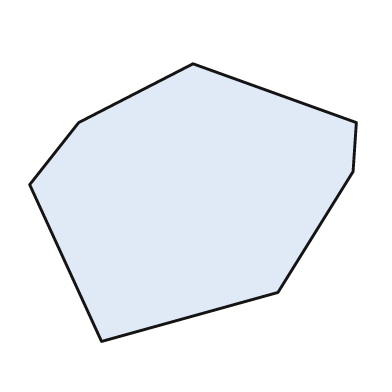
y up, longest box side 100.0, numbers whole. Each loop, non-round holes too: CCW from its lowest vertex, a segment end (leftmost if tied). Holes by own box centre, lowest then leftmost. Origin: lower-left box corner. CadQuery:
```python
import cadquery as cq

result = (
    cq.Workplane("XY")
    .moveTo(22.0, 0.0)
    .lineTo(76.0, 15.0)
    .lineTo(99.0, 52.0)
    .lineTo(100.0, 67.0)
    .lineTo(50.0, 85.0)
    .lineTo(15.0, 67.0)
    .lineTo(0.0, 48.0)
    .close()
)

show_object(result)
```